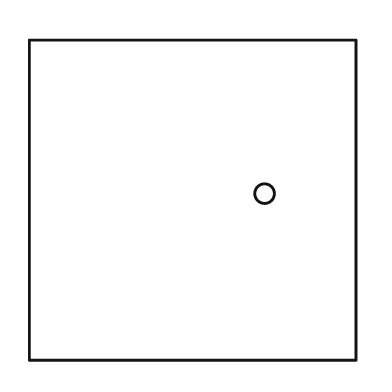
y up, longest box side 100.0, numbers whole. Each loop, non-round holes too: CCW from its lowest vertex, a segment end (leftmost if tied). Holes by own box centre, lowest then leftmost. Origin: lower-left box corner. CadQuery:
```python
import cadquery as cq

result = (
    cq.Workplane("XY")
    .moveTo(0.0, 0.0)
    .lineTo(100.0, 0.0)
    .lineTo(100.0, 98.0)
    .lineTo(0.0, 98.0)
    .close()
    .moveTo(72.0, 51.0)
    .circle(3.0)
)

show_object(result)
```